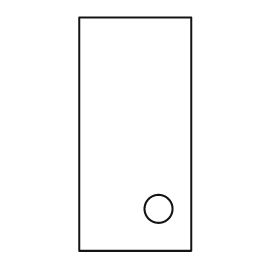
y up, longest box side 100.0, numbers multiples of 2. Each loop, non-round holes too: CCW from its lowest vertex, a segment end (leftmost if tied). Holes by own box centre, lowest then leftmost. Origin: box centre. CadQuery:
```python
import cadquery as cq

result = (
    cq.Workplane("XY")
    .moveTo(-24.0, -50.0)
    .lineTo(24.0, -50.0)
    .lineTo(24.0, 50.0)
    .lineTo(-24.0, 50.0)
    .close()
    .moveTo(10.0, -32.0)
    .circle(6.0)
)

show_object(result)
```